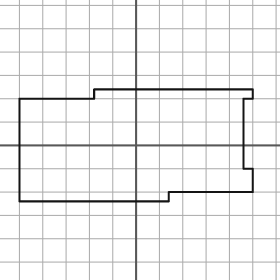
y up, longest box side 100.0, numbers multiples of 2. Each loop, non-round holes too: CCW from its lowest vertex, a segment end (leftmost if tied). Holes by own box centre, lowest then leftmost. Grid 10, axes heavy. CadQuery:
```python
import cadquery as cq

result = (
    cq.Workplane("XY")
    .moveTo(-50.0, -24.0)
    .lineTo(14.0, -24.0)
    .lineTo(14.0, -20.0)
    .lineTo(50.0, -20.0)
    .lineTo(50.0, -10.0)
    .lineTo(46.0, -10.0)
    .lineTo(46.0, 20.0)
    .lineTo(50.0, 20.0)
    .lineTo(50.0, 24.0)
    .lineTo(-18.0, 24.0)
    .lineTo(-18.0, 20.0)
    .lineTo(-50.0, 20.0)
    .close()
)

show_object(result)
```